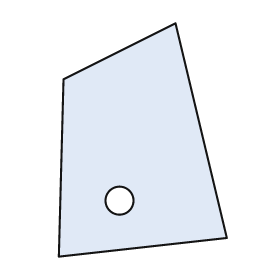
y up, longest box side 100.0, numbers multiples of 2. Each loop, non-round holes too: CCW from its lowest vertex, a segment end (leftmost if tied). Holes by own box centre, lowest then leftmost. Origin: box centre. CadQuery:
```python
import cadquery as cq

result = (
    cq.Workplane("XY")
    .moveTo(-36.0, -50.0)
    .lineTo(36.0, -42.0)
    .lineTo(14.0, 50.0)
    .lineTo(-34.0, 26.0)
    .close()
    .moveTo(-10.0, -26.0)
    .circle(6.0)
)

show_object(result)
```